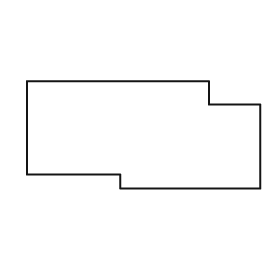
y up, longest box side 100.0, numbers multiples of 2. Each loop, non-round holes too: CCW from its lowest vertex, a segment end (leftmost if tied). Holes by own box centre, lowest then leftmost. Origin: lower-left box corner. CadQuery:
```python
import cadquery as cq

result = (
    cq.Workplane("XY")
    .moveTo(40.0, 0.0)
    .lineTo(100.0, 0.0)
    .lineTo(100.0, 36.0)
    .lineTo(78.0, 36.0)
    .lineTo(78.0, 46.0)
    .lineTo(0.0, 46.0)
    .lineTo(0.0, 6.0)
    .lineTo(40.0, 6.0)
    .close()
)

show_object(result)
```